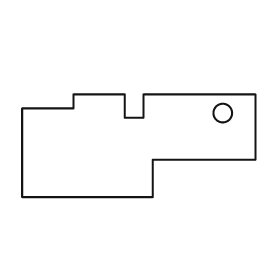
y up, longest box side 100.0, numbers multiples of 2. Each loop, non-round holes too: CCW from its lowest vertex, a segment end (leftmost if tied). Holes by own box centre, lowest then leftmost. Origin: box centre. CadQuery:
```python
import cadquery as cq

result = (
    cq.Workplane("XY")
    .moveTo(-50.0, -22.0)
    .lineTo(6.0, -22.0)
    .lineTo(6.0, -6.0)
    .lineTo(50.0, -6.0)
    .lineTo(50.0, 22.0)
    .lineTo(2.0, 22.0)
    .lineTo(2.0, 12.0)
    .lineTo(-6.0, 12.0)
    .lineTo(-6.0, 22.0)
    .lineTo(-28.0, 22.0)
    .lineTo(-28.0, 16.0)
    .lineTo(-50.0, 16.0)
    .close()
    .moveTo(36.0, 14.0)
    .circle(4.0)
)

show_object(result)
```